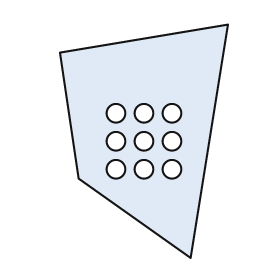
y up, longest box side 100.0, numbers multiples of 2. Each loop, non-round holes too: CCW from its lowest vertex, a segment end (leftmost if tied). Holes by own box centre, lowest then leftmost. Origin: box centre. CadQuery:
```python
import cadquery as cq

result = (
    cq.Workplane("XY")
    .moveTo(20.0, -50.0)
    .lineTo(36.0, 50.0)
    .lineTo(-36.0, 38.0)
    .lineTo(-28.0, -16.0)
    .close()
    .moveTo(-12.0, -12.0)
    .circle(4.0)
    .moveTo(0.0, -12.0)
    .circle(4.0)
    .moveTo(12.0, -12.0)
    .circle(4.0)
    .moveTo(-12.0, 0.0)
    .circle(4.0)
    .moveTo(0.0, 0.0)
    .circle(4.0)
    .moveTo(12.0, 0.0)
    .circle(4.0)
    .moveTo(-12.0, 12.0)
    .circle(4.0)
    .moveTo(0.0, 12.0)
    .circle(4.0)
    .moveTo(12.0, 12.0)
    .circle(4.0)
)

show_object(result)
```